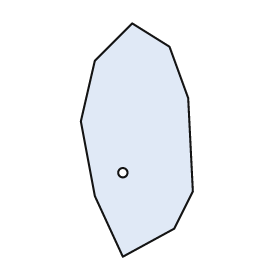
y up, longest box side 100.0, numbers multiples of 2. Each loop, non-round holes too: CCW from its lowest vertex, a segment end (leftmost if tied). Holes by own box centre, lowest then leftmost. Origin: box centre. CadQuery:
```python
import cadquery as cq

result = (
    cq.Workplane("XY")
    .moveTo(-6.0, -50.0)
    .lineTo(16.0, -38.0)
    .lineTo(24.0, -22.0)
    .lineTo(22.0, 18.0)
    .lineTo(14.0, 40.0)
    .lineTo(-2.0, 50.0)
    .lineTo(-18.0, 34.0)
    .lineTo(-24.0, 8.0)
    .lineTo(-18.0, -24.0)
    .close()
    .moveTo(-6.0, -14.0)
    .circle(2.0)
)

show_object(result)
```